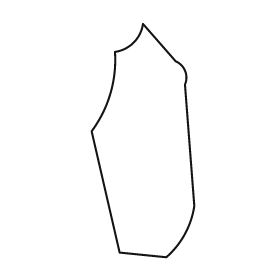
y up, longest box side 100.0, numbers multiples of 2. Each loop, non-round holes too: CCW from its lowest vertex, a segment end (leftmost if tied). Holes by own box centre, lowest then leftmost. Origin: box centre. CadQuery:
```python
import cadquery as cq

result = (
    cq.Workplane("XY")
    .moveTo(10.0, -50.0)
    .threePointArc((18.0, -40.0), (22.0, -28.0))
    .lineTo(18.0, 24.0)
    .threePointArc((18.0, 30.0), (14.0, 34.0))
    .lineTo(0.0, 50.0)
    .threePointArc((-4.0, 42.0), (-12.0, 38.0))
    .threePointArc((-14.0, 20.0), (-22.0, 4.0))
    .lineTo(-10.0, -48.0)
    .close()
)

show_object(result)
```